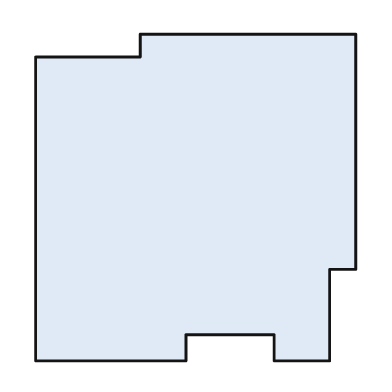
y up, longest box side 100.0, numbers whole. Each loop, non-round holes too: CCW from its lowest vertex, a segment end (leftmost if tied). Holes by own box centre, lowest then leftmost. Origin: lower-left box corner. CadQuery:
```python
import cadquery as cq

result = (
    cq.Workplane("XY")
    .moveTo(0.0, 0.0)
    .lineTo(46.0, 0.0)
    .lineTo(46.0, 8.0)
    .lineTo(73.0, 8.0)
    .lineTo(73.0, 0.0)
    .lineTo(90.0, 0.0)
    .lineTo(90.0, 28.0)
    .lineTo(98.0, 28.0)
    .lineTo(98.0, 100.0)
    .lineTo(32.0, 100.0)
    .lineTo(32.0, 93.0)
    .lineTo(0.0, 93.0)
    .close()
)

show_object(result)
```